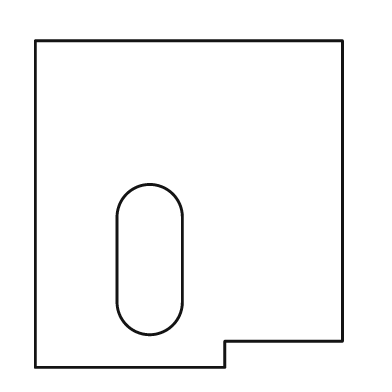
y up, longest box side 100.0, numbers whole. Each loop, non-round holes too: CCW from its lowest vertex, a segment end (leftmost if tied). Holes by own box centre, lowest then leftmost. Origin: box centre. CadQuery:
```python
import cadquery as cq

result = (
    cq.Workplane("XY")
    .moveTo(-47.0, -50.0)
    .lineTo(11.0, -50.0)
    .lineTo(11.0, -42.0)
    .lineTo(47.0, -42.0)
    .lineTo(47.0, 50.0)
    .lineTo(-47.0, 50.0)
    .close()
    .moveTo(-22.0, -30.0)
    .threePointArc((-12.0, -40.0), (-2.0, -30.0))
    .lineTo(-2.0, -4.0)
    .threePointArc((-12.0, 6.0), (-22.0, -4.0))
    .close()
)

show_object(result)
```